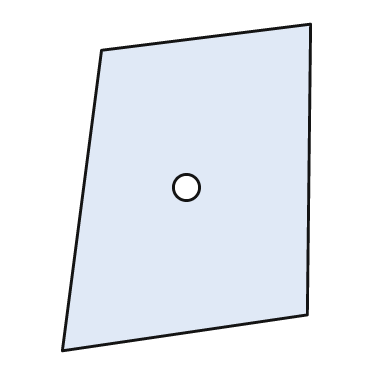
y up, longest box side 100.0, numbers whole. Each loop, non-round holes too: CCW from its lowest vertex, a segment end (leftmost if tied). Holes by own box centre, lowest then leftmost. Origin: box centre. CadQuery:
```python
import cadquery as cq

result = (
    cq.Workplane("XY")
    .moveTo(-38.0, -50.0)
    .lineTo(37.0, -39.0)
    .lineTo(38.0, 50.0)
    .lineTo(-26.0, 42.0)
    .close()
    .moveTo(0.0, 0.0)
    .circle(4.0)
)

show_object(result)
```